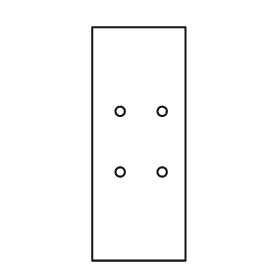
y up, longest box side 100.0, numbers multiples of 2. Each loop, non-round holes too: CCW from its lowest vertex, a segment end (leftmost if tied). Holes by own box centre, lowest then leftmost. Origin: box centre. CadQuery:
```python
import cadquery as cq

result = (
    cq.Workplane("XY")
    .moveTo(-20.0, -50.0)
    .lineTo(20.0, -50.0)
    .lineTo(20.0, 50.0)
    .lineTo(-20.0, 50.0)
    .close()
    .moveTo(-8.0, -12.0)
    .circle(2.0)
    .moveTo(10.0, -12.0)
    .circle(2.0)
    .moveTo(-8.0, 14.0)
    .circle(2.0)
    .moveTo(10.0, 14.0)
    .circle(2.0)
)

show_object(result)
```